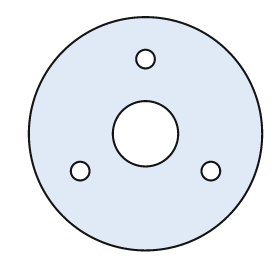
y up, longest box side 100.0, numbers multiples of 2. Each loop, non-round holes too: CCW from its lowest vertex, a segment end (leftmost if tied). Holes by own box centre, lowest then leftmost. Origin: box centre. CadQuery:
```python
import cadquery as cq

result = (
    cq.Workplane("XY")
    .moveTo(0.0, 0.0)
    .circle(50.0)
    .moveTo(-28.0, -16.0)
    .circle(4.0)
    .moveTo(28.0, -16.0)
    .circle(4.0)
    .moveTo(0.0, 0.0)
    .circle(14.0)
    .moveTo(0.0, 32.0)
    .circle(4.0)
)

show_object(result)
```